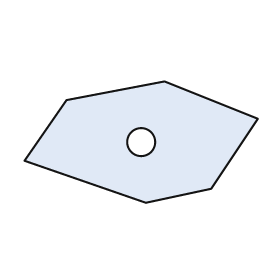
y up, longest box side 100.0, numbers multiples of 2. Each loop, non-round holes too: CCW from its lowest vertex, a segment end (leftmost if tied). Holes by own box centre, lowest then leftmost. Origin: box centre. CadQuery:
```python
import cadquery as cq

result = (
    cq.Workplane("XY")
    .moveTo(2.0, -26.0)
    .lineTo(30.0, -20.0)
    .lineTo(50.0, 10.0)
    .lineTo(10.0, 26.0)
    .lineTo(-32.0, 18.0)
    .lineTo(-50.0, -8.0)
    .close()
    .moveTo(0.0, 0.0)
    .circle(6.0)
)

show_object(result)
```